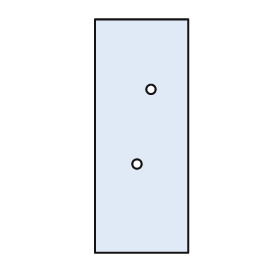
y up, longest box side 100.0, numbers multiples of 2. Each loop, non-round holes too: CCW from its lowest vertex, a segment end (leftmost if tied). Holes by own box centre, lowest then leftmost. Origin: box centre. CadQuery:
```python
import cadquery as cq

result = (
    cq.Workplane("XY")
    .moveTo(-20.0, -50.0)
    .lineTo(20.0, -50.0)
    .lineTo(20.0, 50.0)
    .lineTo(-20.0, 50.0)
    .close()
    .moveTo(-2.0, -12.0)
    .circle(2.0)
    .moveTo(4.0, 20.0)
    .circle(2.0)
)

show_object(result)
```